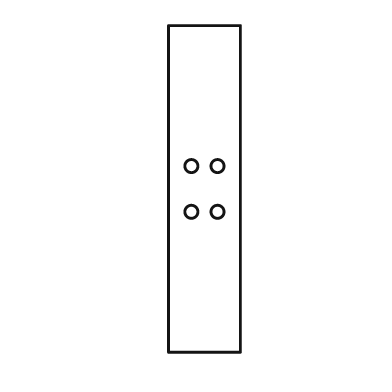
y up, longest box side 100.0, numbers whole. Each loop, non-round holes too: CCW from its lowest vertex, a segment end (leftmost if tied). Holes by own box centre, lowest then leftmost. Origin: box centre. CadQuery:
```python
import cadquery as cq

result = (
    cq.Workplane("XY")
    .moveTo(-11.0, -50.0)
    .lineTo(11.0, -50.0)
    .lineTo(11.0, 50.0)
    .lineTo(-11.0, 50.0)
    .close()
    .moveTo(-4.0, -7.0)
    .circle(2.0)
    .moveTo(4.0, -7.0)
    .circle(2.0)
    .moveTo(-4.0, 7.0)
    .circle(2.0)
    .moveTo(4.0, 7.0)
    .circle(2.0)
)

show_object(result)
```